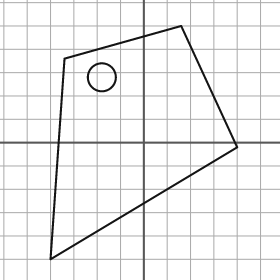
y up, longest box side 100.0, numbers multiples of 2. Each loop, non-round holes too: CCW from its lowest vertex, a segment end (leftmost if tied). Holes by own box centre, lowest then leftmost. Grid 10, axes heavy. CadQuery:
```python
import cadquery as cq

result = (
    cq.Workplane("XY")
    .moveTo(-40.0, -50.0)
    .lineTo(40.0, -2.0)
    .lineTo(16.0, 50.0)
    .lineTo(-34.0, 36.0)
    .close()
    .moveTo(-18.0, 28.0)
    .circle(6.0)
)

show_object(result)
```